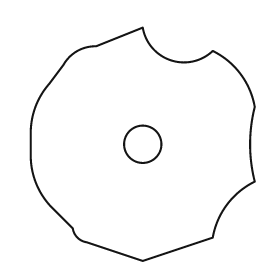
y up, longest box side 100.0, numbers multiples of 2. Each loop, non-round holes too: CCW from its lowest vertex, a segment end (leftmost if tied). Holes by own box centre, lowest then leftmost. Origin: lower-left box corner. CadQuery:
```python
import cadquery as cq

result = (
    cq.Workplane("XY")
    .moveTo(48.0, 0.0)
    .lineTo(78.0, 10.0)
    .threePointArc((84.0, 24.0), (96.0, 34.0))
    .threePointArc((94.0, 50.0), (96.0, 66.0))
    .threePointArc((90.0, 80.0), (78.0, 90.0))
    .threePointArc((60.0, 86.0), (48.0, 100.0))
    .lineTo(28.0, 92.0)
    .threePointArc((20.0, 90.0), (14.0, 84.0))
    .lineTo(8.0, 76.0)
    .threePointArc((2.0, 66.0), (0.0, 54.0))
    .lineTo(0.0, 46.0)
    .threePointArc((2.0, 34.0), (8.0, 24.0))
    .lineTo(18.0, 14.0)
    .threePointArc((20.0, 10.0), (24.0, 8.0))
    .close()
    .moveTo(48.0, 50.0)
    .circle(8.0)
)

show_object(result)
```